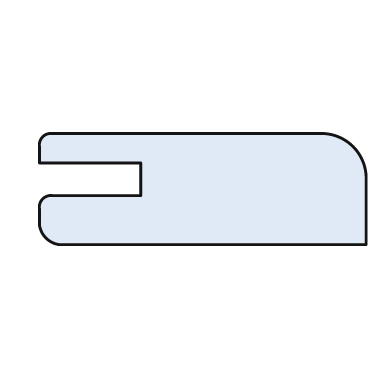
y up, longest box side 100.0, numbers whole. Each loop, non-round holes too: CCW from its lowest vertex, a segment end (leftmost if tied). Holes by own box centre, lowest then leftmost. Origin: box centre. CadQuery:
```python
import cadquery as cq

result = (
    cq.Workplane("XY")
    .moveTo(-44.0, -17.0)
    .lineTo(50.0, -17.0)
    .lineTo(50.0, 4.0)
    .threePointArc((46.0, 13.0), (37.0, 17.0))
    .lineTo(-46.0, 17.0)
    .threePointArc((-49.0, 16.0), (-50.0, 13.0))
    .lineTo(-50.0, 8.0)
    .lineTo(-19.0, 8.0)
    .lineTo(-19.0, -2.0)
    .lineTo(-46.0, -2.0)
    .threePointArc((-49.0, -3.0), (-50.0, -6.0))
    .lineTo(-50.0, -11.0)
    .threePointArc((-48.0, -15.0), (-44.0, -17.0))
    .close()
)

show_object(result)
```